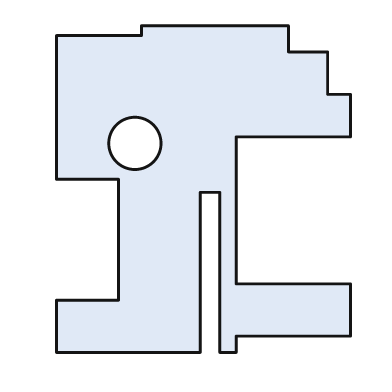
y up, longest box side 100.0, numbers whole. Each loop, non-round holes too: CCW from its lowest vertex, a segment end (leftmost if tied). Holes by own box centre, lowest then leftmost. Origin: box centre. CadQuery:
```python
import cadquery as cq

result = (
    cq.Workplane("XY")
    .moveTo(-45.0, -50.0)
    .lineTo(-1.0, -50.0)
    .lineTo(-1.0, -1.0)
    .lineTo(5.0, -1.0)
    .lineTo(5.0, -50.0)
    .lineTo(10.0, -50.0)
    .lineTo(10.0, -45.0)
    .lineTo(45.0, -45.0)
    .lineTo(45.0, -29.0)
    .lineTo(10.0, -29.0)
    .lineTo(10.0, 16.0)
    .lineTo(45.0, 16.0)
    .lineTo(45.0, 29.0)
    .lineTo(38.0, 29.0)
    .lineTo(38.0, 42.0)
    .lineTo(26.0, 42.0)
    .lineTo(26.0, 50.0)
    .lineTo(-19.0, 50.0)
    .lineTo(-19.0, 47.0)
    .lineTo(-45.0, 47.0)
    .lineTo(-45.0, 3.0)
    .lineTo(-26.0, 3.0)
    .lineTo(-26.0, -34.0)
    .lineTo(-45.0, -34.0)
    .close()
    .moveTo(-21.0, 14.0)
    .circle(8.0)
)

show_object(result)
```